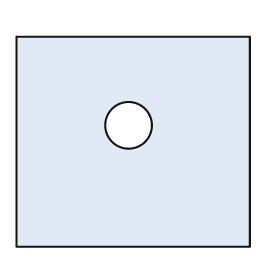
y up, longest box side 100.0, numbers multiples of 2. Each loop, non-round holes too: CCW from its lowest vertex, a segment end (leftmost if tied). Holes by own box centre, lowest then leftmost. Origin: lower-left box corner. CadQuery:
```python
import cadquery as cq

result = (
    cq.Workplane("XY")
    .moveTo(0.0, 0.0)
    .lineTo(100.0, 0.0)
    .lineTo(100.0, 90.0)
    .lineTo(0.0, 90.0)
    .close()
    .moveTo(48.0, 52.0)
    .circle(10.0)
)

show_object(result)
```